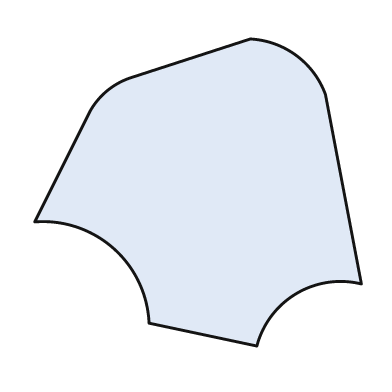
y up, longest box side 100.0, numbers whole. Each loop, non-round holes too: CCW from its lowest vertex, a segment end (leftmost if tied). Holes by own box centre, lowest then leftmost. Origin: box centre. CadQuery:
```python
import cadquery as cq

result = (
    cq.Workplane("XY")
    .moveTo(18.0, -47.0)
    .threePointArc((30.0, -31.0), (50.0, -28.0))
    .lineTo(39.0, 30.0)
    .threePointArc((30.0, 42.0), (16.0, 47.0))
    .lineTo(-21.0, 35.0)
    .threePointArc((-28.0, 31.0), (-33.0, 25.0))
    .lineTo(-50.0, -9.0)
    .threePointArc((-26.0, -17.0), (-15.0, -40.0))
    .close()
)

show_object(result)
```